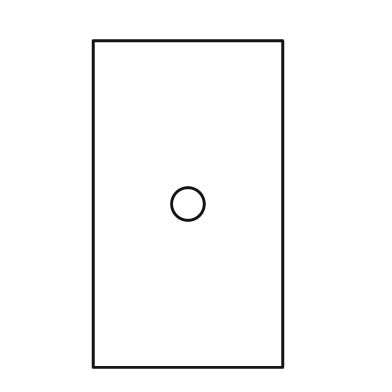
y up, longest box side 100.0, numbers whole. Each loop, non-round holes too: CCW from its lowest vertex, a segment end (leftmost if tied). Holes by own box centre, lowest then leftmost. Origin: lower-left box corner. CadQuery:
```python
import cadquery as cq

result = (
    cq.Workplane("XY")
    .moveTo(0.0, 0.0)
    .lineTo(58.0, 0.0)
    .lineTo(58.0, 100.0)
    .lineTo(0.0, 100.0)
    .close()
    .moveTo(29.0, 50.0)
    .circle(5.0)
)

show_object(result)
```